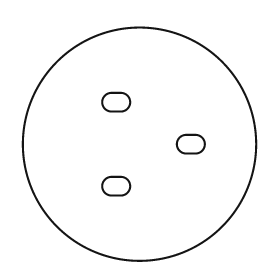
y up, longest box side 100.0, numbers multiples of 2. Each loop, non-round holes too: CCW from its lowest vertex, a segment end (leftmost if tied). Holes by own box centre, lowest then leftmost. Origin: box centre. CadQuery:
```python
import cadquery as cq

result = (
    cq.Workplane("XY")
    .moveTo(0.0, 0.0)
    .circle(50.0)
    .moveTo(-12.0, -22.0)
    .lineTo(-8.0, -22.0)
    .threePointArc((-4.0, -18.0), (-8.0, -14.0))
    .lineTo(-12.0, -14.0)
    .threePointArc((-16.0, -18.0), (-12.0, -22.0))
    .close()
    .moveTo(20.0, -4.0)
    .lineTo(24.0, -4.0)
    .threePointArc((28.0, 0.0), (24.0, 4.0))
    .lineTo(20.0, 4.0)
    .threePointArc((16.0, 0.0), (20.0, -4.0))
    .close()
    .moveTo(-12.0, 14.0)
    .lineTo(-8.0, 14.0)
    .threePointArc((-4.0, 18.0), (-8.0, 22.0))
    .lineTo(-12.0, 22.0)
    .threePointArc((-16.0, 18.0), (-12.0, 14.0))
    .close()
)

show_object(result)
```